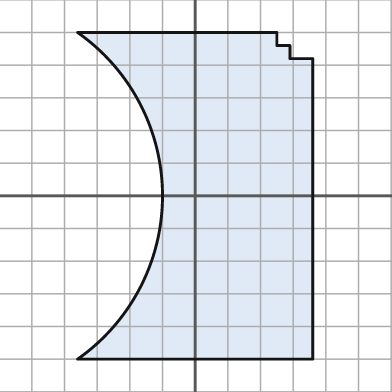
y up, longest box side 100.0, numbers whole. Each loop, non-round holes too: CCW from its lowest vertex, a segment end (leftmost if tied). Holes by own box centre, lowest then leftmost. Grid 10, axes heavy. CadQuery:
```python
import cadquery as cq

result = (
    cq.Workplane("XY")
    .moveTo(-36.0, -50.0)
    .lineTo(36.0, -50.0)
    .lineTo(36.0, 42.0)
    .lineTo(29.0, 42.0)
    .lineTo(29.0, 46.0)
    .lineTo(25.0, 46.0)
    .lineTo(25.0, 50.0)
    .lineTo(-36.0, 50.0)
    .threePointArc((-10.0, 0.0), (-36.0, -50.0))
    .close()
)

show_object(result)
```